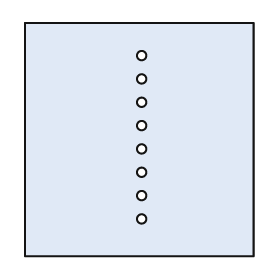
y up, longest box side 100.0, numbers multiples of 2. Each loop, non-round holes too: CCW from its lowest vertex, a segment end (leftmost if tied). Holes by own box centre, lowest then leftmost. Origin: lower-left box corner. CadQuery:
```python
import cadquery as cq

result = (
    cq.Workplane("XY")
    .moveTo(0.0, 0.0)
    .lineTo(98.0, 0.0)
    .lineTo(98.0, 100.0)
    .lineTo(0.0, 100.0)
    .close()
    .moveTo(50.0, 16.0)
    .circle(2.0)
    .moveTo(50.0, 26.0)
    .circle(2.0)
    .moveTo(50.0, 36.0)
    .circle(2.0)
    .moveTo(50.0, 46.0)
    .circle(2.0)
    .moveTo(50.0, 56.0)
    .circle(2.0)
    .moveTo(50.0, 66.0)
    .circle(2.0)
    .moveTo(50.0, 76.0)
    .circle(2.0)
    .moveTo(50.0, 86.0)
    .circle(2.0)
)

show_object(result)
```